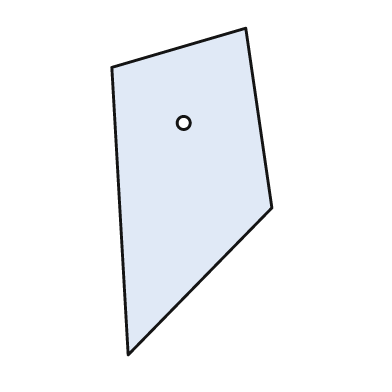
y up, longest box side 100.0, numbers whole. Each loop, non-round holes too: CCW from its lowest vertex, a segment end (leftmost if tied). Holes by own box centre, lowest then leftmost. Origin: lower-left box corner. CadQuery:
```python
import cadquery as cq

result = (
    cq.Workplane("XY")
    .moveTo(5.0, 0.0)
    .lineTo(49.0, 45.0)
    .lineTo(41.0, 100.0)
    .lineTo(0.0, 88.0)
    .close()
    .moveTo(22.0, 71.0)
    .circle(2.0)
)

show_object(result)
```